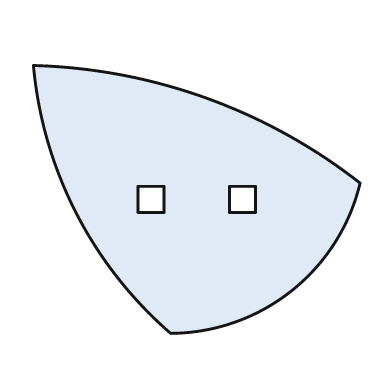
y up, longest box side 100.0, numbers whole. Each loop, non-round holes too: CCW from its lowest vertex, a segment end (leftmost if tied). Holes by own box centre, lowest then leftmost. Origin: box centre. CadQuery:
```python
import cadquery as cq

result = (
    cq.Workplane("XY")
    .moveTo(-8.0, -41.0)
    .threePointArc((29.0, -28.0), (50.0, 5.0))
    .threePointArc((3.0, 31.0), (-50.0, 41.0))
    .threePointArc((-37.0, -4.0), (-8.0, -41.0))
    .close()
    .moveTo(-18.0, -4.0)
    .lineTo(-10.0, -4.0)
    .lineTo(-10.0, 4.0)
    .lineTo(-18.0, 4.0)
    .close()
    .moveTo(10.0, -4.0)
    .lineTo(18.0, -4.0)
    .lineTo(18.0, 4.0)
    .lineTo(10.0, 4.0)
    .close()
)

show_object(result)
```